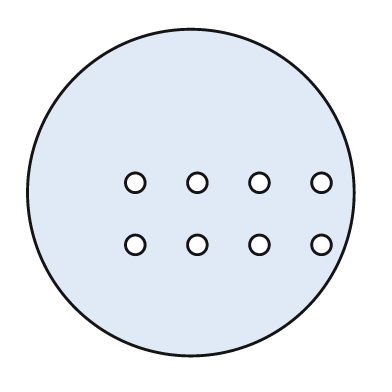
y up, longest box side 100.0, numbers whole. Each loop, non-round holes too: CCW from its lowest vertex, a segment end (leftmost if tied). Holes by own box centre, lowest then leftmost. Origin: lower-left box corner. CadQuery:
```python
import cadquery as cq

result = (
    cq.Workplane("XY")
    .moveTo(50.0, 50.0)
    .circle(50.0)
    .moveTo(33.0, 34.0)
    .circle(3.0)
    .moveTo(52.0, 34.0)
    .circle(3.0)
    .moveTo(71.0, 34.0)
    .circle(3.0)
    .moveTo(90.0, 34.0)
    .circle(3.0)
    .moveTo(33.0, 53.0)
    .circle(3.0)
    .moveTo(52.0, 53.0)
    .circle(3.0)
    .moveTo(71.0, 53.0)
    .circle(3.0)
    .moveTo(90.0, 53.0)
    .circle(3.0)
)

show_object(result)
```